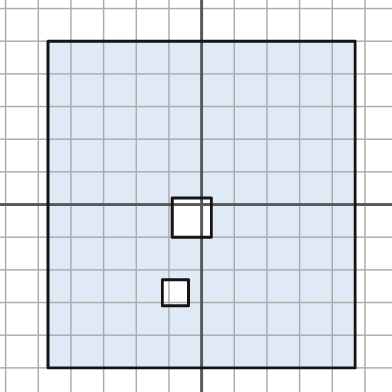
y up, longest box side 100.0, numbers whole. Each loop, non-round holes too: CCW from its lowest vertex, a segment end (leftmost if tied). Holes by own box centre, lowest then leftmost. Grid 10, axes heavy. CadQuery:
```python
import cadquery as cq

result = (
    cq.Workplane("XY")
    .moveTo(-47.0, -50.0)
    .lineTo(47.0, -50.0)
    .lineTo(47.0, 50.0)
    .lineTo(-47.0, 50.0)
    .close()
    .moveTo(-12.0, -31.0)
    .lineTo(-4.0, -31.0)
    .lineTo(-4.0, -23.0)
    .lineTo(-12.0, -23.0)
    .close()
    .moveTo(-9.0, -10.0)
    .lineTo(3.0, -10.0)
    .lineTo(3.0, 2.0)
    .lineTo(-9.0, 2.0)
    .close()
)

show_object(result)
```